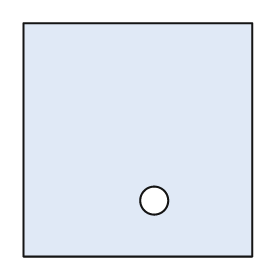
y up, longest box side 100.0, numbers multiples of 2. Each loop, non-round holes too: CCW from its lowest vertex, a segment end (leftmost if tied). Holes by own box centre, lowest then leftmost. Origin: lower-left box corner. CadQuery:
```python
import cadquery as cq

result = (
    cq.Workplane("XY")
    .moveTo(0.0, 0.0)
    .lineTo(98.0, 0.0)
    .lineTo(98.0, 100.0)
    .lineTo(0.0, 100.0)
    .close()
    .moveTo(56.0, 24.0)
    .circle(6.0)
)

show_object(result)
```